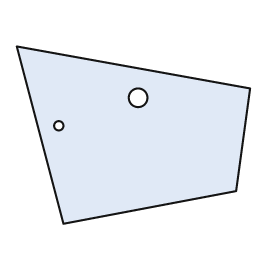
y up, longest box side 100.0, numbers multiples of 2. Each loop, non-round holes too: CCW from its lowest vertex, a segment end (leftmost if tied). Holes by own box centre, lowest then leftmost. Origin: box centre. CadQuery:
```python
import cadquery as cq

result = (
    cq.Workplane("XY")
    .moveTo(-30.0, -38.0)
    .lineTo(44.0, -24.0)
    .lineTo(50.0, 20.0)
    .lineTo(-50.0, 38.0)
    .close()
    .moveTo(-32.0, 4.0)
    .circle(2.0)
    .moveTo(2.0, 16.0)
    .circle(4.0)
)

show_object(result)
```